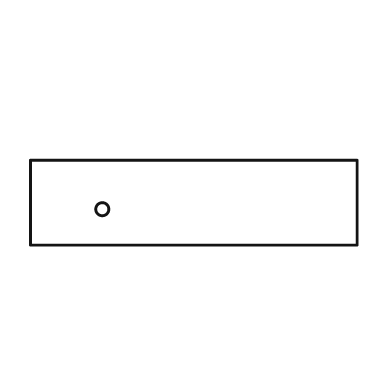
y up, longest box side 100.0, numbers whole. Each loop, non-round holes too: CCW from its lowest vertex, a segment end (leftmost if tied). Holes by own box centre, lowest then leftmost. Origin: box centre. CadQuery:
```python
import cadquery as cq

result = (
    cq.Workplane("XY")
    .moveTo(-50.0, -13.0)
    .lineTo(50.0, -13.0)
    .lineTo(50.0, 13.0)
    .lineTo(-50.0, 13.0)
    .close()
    .moveTo(-28.0, -2.0)
    .circle(2.0)
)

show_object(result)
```